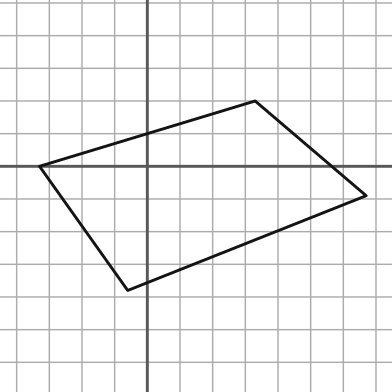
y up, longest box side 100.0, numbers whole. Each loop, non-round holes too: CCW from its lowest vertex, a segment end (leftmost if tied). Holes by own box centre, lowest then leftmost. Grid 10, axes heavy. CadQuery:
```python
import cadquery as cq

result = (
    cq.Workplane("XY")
    .moveTo(-6.0, -38.0)
    .lineTo(67.0, -9.0)
    .lineTo(33.0, 20.0)
    .lineTo(-33.0, 0.0)
    .close()
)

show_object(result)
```